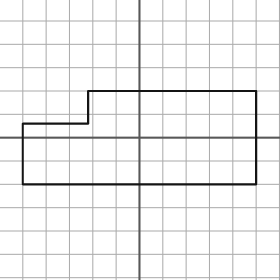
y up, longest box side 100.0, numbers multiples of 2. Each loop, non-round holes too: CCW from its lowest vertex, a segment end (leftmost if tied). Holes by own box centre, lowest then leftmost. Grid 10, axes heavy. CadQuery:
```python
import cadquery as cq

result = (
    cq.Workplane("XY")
    .moveTo(-50.0, -20.0)
    .lineTo(50.0, -20.0)
    .lineTo(50.0, 20.0)
    .lineTo(-22.0, 20.0)
    .lineTo(-22.0, 6.0)
    .lineTo(-50.0, 6.0)
    .close()
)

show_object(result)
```